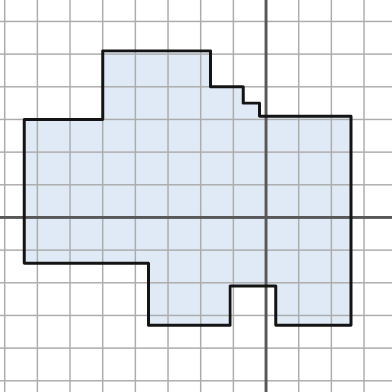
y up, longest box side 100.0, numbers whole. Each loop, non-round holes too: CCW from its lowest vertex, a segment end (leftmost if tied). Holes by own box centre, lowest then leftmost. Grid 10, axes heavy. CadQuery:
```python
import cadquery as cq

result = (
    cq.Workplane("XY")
    .moveTo(-36.0, -33.0)
    .lineTo(-11.0, -33.0)
    .lineTo(-11.0, -21.0)
    .lineTo(3.0, -21.0)
    .lineTo(3.0, -33.0)
    .lineTo(26.0, -33.0)
    .lineTo(26.0, 31.0)
    .lineTo(-2.0, 31.0)
    .lineTo(-2.0, 35.0)
    .lineTo(-7.0, 35.0)
    .lineTo(-7.0, 40.0)
    .lineTo(-17.0, 40.0)
    .lineTo(-17.0, 51.0)
    .lineTo(-50.0, 51.0)
    .lineTo(-50.0, 30.0)
    .lineTo(-74.0, 30.0)
    .lineTo(-74.0, -14.0)
    .lineTo(-36.0, -14.0)
    .close()
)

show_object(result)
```